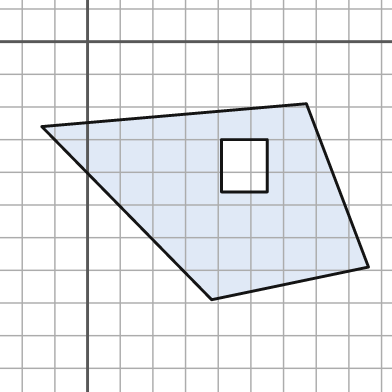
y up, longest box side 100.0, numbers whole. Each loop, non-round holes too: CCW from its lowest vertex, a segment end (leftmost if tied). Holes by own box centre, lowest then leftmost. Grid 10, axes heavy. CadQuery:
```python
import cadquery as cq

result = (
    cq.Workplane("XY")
    .moveTo(38.0, -79.0)
    .lineTo(86.0, -69.0)
    .lineTo(67.0, -19.0)
    .lineTo(-14.0, -26.0)
    .close()
    .moveTo(41.0, -46.0)
    .lineTo(55.0, -46.0)
    .lineTo(55.0, -30.0)
    .lineTo(41.0, -30.0)
    .close()
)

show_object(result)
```